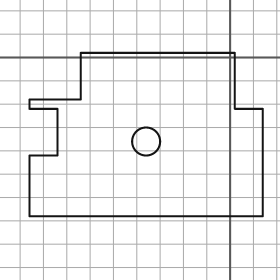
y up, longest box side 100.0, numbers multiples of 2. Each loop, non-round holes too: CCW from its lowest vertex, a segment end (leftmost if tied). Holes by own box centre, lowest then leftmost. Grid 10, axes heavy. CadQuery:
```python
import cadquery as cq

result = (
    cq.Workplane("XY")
    .moveTo(-86.0, -68.0)
    .lineTo(14.0, -68.0)
    .lineTo(14.0, -22.0)
    .lineTo(2.0, -22.0)
    .lineTo(2.0, 2.0)
    .lineTo(-64.0, 2.0)
    .lineTo(-64.0, -18.0)
    .lineTo(-86.0, -18.0)
    .lineTo(-86.0, -22.0)
    .lineTo(-74.0, -22.0)
    .lineTo(-74.0, -42.0)
    .lineTo(-86.0, -42.0)
    .close()
    .moveTo(-36.0, -36.0)
    .circle(6.0)
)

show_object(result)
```